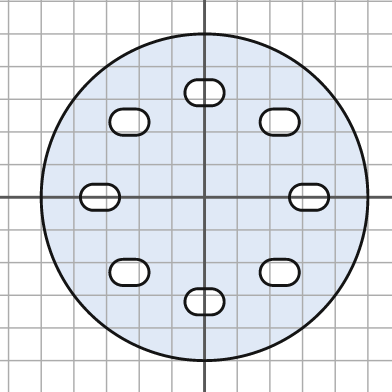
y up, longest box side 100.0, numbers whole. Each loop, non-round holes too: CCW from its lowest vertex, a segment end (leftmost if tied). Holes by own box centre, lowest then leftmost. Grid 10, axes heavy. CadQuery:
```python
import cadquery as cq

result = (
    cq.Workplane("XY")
    .moveTo(0.0, 0.0)
    .circle(50.0)
    .moveTo(-2.0, -36.0)
    .lineTo(2.0, -36.0)
    .threePointArc((6.0, -32.0), (2.0, -28.0))
    .lineTo(-2.0, -28.0)
    .threePointArc((-6.0, -32.0), (-2.0, -36.0))
    .close()
    .moveTo(-25.0, -27.0)
    .lineTo(-21.0, -27.0)
    .threePointArc((-17.0, -23.0), (-21.0, -19.0))
    .lineTo(-25.0, -19.0)
    .threePointArc((-29.0, -23.0), (-25.0, -27.0))
    .close()
    .moveTo(21.0, -27.0)
    .lineTo(25.0, -27.0)
    .threePointArc((29.0, -23.0), (25.0, -19.0))
    .lineTo(21.0, -19.0)
    .threePointArc((17.0, -23.0), (21.0, -27.0))
    .close()
    .moveTo(-34.0, -4.0)
    .lineTo(-30.0, -4.0)
    .threePointArc((-26.0, 0.0), (-30.0, 4.0))
    .lineTo(-34.0, 4.0)
    .threePointArc((-38.0, 0.0), (-34.0, -4.0))
    .close()
    .moveTo(30.0, -4.0)
    .lineTo(34.0, -4.0)
    .threePointArc((38.0, 0.0), (34.0, 4.0))
    .lineTo(30.0, 4.0)
    .threePointArc((26.0, 0.0), (30.0, -4.0))
    .close()
    .moveTo(-25.0, 19.0)
    .lineTo(-21.0, 19.0)
    .threePointArc((-17.0, 23.0), (-21.0, 27.0))
    .lineTo(-25.0, 27.0)
    .threePointArc((-29.0, 23.0), (-25.0, 19.0))
    .close()
    .moveTo(21.0, 19.0)
    .lineTo(25.0, 19.0)
    .threePointArc((29.0, 23.0), (25.0, 27.0))
    .lineTo(21.0, 27.0)
    .threePointArc((17.0, 23.0), (21.0, 19.0))
    .close()
    .moveTo(-2.0, 28.0)
    .lineTo(2.0, 28.0)
    .threePointArc((6.0, 32.0), (2.0, 36.0))
    .lineTo(-2.0, 36.0)
    .threePointArc((-6.0, 32.0), (-2.0, 28.0))
    .close()
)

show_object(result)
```